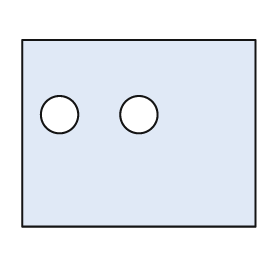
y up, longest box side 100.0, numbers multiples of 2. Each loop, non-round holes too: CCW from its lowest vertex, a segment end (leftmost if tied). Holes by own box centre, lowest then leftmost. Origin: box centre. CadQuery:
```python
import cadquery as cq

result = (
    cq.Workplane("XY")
    .moveTo(-50.0, -40.0)
    .lineTo(50.0, -40.0)
    .lineTo(50.0, 40.0)
    .lineTo(-50.0, 40.0)
    .close()
    .moveTo(-34.0, 8.0)
    .circle(8.0)
    .moveTo(0.0, 8.0)
    .circle(8.0)
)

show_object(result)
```